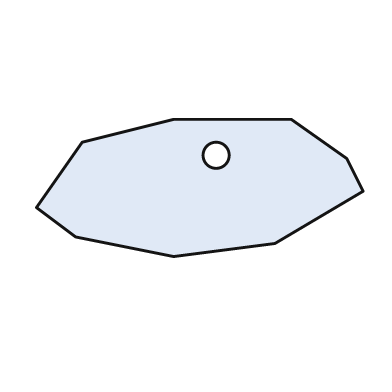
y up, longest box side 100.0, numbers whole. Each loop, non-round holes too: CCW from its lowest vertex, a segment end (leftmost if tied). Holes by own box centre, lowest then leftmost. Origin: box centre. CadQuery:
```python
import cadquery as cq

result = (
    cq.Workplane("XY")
    .moveTo(-8.0, -21.0)
    .lineTo(23.0, -17.0)
    .lineTo(50.0, -1.0)
    .lineTo(45.0, 9.0)
    .lineTo(28.0, 21.0)
    .lineTo(-8.0, 21.0)
    .lineTo(-36.0, 14.0)
    .lineTo(-50.0, -6.0)
    .lineTo(-38.0, -15.0)
    .close()
    .moveTo(5.0, 10.0)
    .circle(4.0)
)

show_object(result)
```